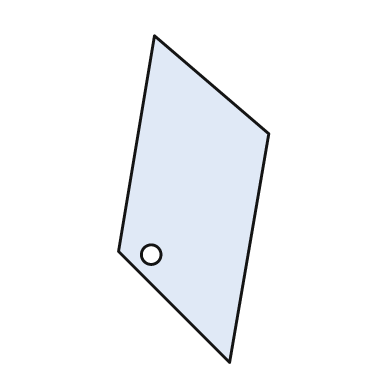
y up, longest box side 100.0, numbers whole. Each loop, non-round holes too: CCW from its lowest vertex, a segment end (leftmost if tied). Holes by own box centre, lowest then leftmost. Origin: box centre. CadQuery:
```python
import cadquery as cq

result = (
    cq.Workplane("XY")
    .moveTo(11.0, -50.0)
    .lineTo(23.0, 20.0)
    .lineTo(-12.0, 50.0)
    .lineTo(-23.0, -16.0)
    .close()
    .moveTo(-13.0, -17.0)
    .circle(3.0)
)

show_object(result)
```